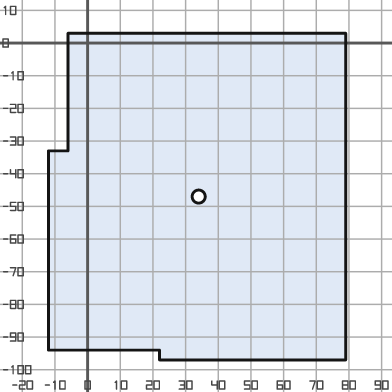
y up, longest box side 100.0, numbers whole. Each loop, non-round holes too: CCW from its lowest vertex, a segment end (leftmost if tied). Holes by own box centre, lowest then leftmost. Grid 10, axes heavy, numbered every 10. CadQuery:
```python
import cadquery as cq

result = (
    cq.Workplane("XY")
    .moveTo(22.0, -97.0)
    .lineTo(79.0, -97.0)
    .lineTo(79.0, 3.0)
    .lineTo(-6.0, 3.0)
    .lineTo(-6.0, -33.0)
    .lineTo(-12.0, -33.0)
    .lineTo(-12.0, -94.0)
    .lineTo(22.0, -94.0)
    .close()
    .moveTo(34.0, -47.0)
    .circle(2.0)
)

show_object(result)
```